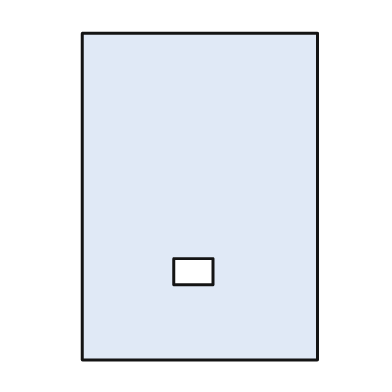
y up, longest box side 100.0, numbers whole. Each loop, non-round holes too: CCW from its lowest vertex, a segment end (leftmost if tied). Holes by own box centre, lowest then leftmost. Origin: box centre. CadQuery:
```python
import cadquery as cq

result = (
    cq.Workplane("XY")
    .moveTo(-36.0, -50.0)
    .lineTo(36.0, -50.0)
    .lineTo(36.0, 50.0)
    .lineTo(-36.0, 50.0)
    .close()
    .moveTo(-8.0, -27.0)
    .lineTo(4.0, -27.0)
    .lineTo(4.0, -19.0)
    .lineTo(-8.0, -19.0)
    .close()
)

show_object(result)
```